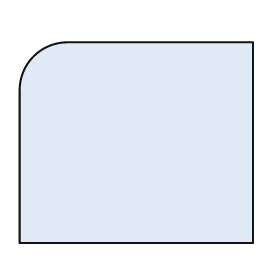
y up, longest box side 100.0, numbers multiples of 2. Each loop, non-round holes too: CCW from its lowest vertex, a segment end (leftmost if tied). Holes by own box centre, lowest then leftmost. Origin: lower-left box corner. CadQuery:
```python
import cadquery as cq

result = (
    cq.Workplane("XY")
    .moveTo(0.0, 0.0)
    .lineTo(100.0, 0.0)
    .lineTo(100.0, 86.0)
    .lineTo(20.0, 86.0)
    .threePointArc((6.0, 80.0), (0.0, 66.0))
    .close()
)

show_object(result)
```